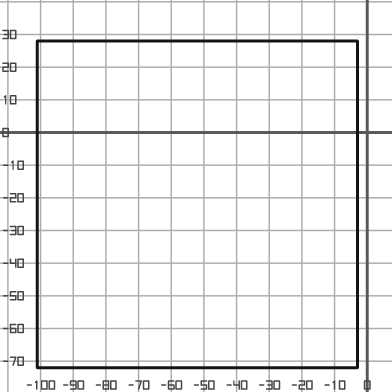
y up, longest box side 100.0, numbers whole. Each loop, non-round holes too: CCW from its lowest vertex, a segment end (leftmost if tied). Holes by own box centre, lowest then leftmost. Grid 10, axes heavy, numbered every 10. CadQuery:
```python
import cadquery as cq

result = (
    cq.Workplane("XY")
    .moveTo(-101.0, -72.0)
    .lineTo(-3.0, -72.0)
    .lineTo(-3.0, 28.0)
    .lineTo(-101.0, 28.0)
    .close()
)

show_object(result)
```